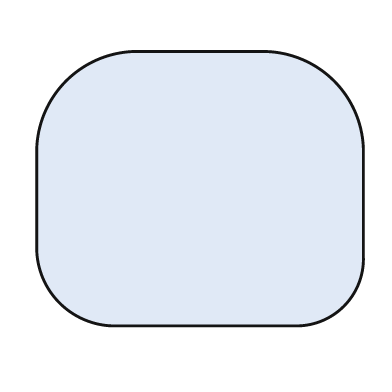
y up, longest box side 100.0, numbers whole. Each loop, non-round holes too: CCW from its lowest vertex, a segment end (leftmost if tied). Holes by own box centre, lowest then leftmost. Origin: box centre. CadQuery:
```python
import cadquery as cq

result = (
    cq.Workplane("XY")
    .moveTo(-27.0, -42.0)
    .lineTo(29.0, -42.0)
    .threePointArc((44.0, -36.0), (50.0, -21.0))
    .lineTo(50.0, 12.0)
    .threePointArc((41.0, 33.0), (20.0, 42.0))
    .lineTo(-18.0, 42.0)
    .threePointArc((-41.0, 33.0), (-50.0, 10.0))
    .lineTo(-50.0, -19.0)
    .threePointArc((-43.0, -35.0), (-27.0, -42.0))
    .close()
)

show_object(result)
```